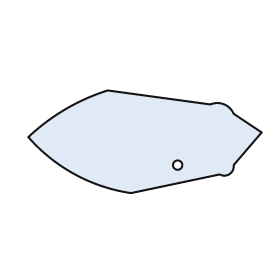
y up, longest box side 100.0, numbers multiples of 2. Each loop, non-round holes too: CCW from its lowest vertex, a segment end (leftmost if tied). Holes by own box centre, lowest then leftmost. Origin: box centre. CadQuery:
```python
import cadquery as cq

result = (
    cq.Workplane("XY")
    .moveTo(-6.0, -22.0)
    .lineTo(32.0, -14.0)
    .threePointArc((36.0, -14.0), (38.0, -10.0))
    .lineTo(50.0, 4.0)
    .lineTo(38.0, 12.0)
    .threePointArc((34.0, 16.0), (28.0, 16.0))
    .lineTo(-16.0, 22.0)
    .threePointArc((-34.0, 14.0), (-50.0, 2.0))
    .threePointArc((-30.0, -14.0), (-6.0, -22.0))
    .close()
    .moveTo(14.0, -10.0)
    .circle(2.0)
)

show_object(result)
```